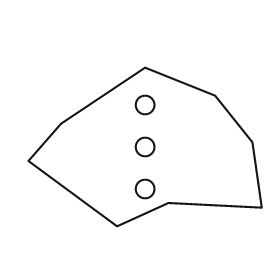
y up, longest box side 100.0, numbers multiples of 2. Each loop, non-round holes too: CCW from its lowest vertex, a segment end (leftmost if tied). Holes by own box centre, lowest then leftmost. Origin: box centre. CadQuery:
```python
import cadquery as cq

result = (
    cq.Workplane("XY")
    .moveTo(-12.0, -34.0)
    .lineTo(10.0, -24.0)
    .lineTo(50.0, -26.0)
    .lineTo(46.0, 2.0)
    .lineTo(30.0, 22.0)
    .lineTo(0.0, 34.0)
    .lineTo(-36.0, 10.0)
    .lineTo(-50.0, -6.0)
    .close()
    .moveTo(0.0, -18.0)
    .circle(4.0)
    .moveTo(0.0, 0.0)
    .circle(4.0)
    .moveTo(0.0, 18.0)
    .circle(4.0)
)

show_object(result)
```